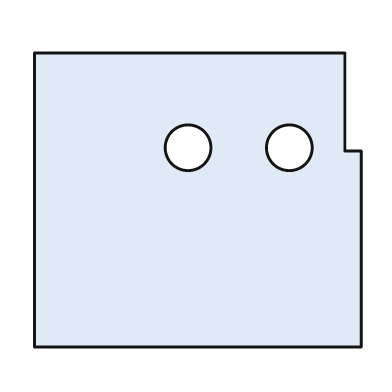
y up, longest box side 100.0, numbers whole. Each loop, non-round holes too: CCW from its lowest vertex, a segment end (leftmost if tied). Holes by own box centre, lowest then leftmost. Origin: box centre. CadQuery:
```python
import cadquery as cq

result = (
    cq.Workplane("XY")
    .moveTo(-50.0, -45.0)
    .lineTo(50.0, -45.0)
    .lineTo(50.0, 15.0)
    .lineTo(45.0, 15.0)
    .lineTo(45.0, 45.0)
    .lineTo(-50.0, 45.0)
    .close()
    .moveTo(-3.0, 16.0)
    .circle(7.0)
    .moveTo(28.0, 16.0)
    .circle(7.0)
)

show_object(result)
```